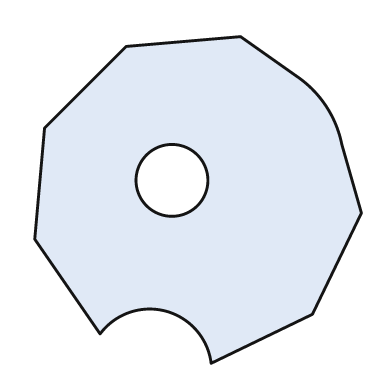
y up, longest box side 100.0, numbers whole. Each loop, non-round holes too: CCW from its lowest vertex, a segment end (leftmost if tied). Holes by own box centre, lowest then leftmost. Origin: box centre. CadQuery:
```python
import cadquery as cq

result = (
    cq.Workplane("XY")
    .moveTo(4.0, -50.0)
    .lineTo(35.0, -35.0)
    .lineTo(50.0, -4.0)
    .lineTo(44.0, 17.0)
    .threePointArc((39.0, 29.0), (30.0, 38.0))
    .lineTo(13.0, 50.0)
    .lineTo(-22.0, 47.0)
    .lineTo(-47.0, 22.0)
    .lineTo(-50.0, -12.0)
    .lineTo(-30.0, -41.0)
    .threePointArc((-10.0, -34.0), (4.0, -50.0))
    .close()
    .moveTo(-8.0, 6.0)
    .circle(11.0)
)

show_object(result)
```